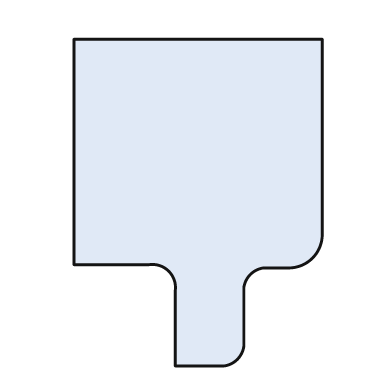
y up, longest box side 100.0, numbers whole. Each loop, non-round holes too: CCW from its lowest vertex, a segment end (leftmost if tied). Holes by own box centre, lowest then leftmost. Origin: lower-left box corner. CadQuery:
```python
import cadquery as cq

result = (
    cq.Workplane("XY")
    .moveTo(31.0, 0.0)
    .lineTo(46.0, 0.0)
    .threePointArc((50.0, 2.0), (52.0, 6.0))
    .lineTo(52.0, 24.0)
    .threePointArc((54.0, 28.0), (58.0, 30.0))
    .lineTo(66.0, 30.0)
    .threePointArc((73.0, 33.0), (76.0, 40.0))
    .lineTo(76.0, 100.0)
    .lineTo(0.0, 100.0)
    .lineTo(0.0, 31.0)
    .lineTo(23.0, 31.0)
    .threePointArc((29.0, 29.0), (31.0, 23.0))
    .close()
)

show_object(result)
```